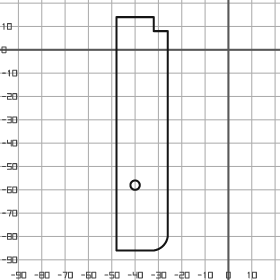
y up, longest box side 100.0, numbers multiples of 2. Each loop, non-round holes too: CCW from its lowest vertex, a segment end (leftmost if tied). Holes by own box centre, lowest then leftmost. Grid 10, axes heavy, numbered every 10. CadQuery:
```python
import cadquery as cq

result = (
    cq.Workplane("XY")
    .moveTo(-48.0, -86.0)
    .lineTo(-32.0, -86.0)
    .threePointArc((-28.0, -84.0), (-26.0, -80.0))
    .lineTo(-26.0, 8.0)
    .lineTo(-32.0, 8.0)
    .lineTo(-32.0, 14.0)
    .lineTo(-48.0, 14.0)
    .close()
    .moveTo(-40.0, -58.0)
    .circle(2.0)
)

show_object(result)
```